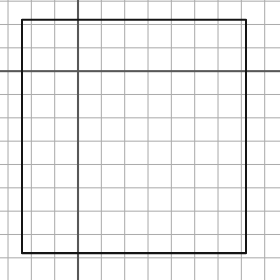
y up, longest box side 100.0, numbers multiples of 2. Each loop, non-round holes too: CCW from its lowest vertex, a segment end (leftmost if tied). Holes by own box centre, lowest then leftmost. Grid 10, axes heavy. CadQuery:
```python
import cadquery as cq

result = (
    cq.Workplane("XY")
    .moveTo(-24.0, -78.0)
    .lineTo(72.0, -78.0)
    .lineTo(72.0, 22.0)
    .lineTo(-24.0, 22.0)
    .close()
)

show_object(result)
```